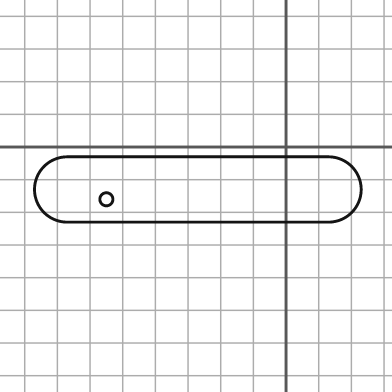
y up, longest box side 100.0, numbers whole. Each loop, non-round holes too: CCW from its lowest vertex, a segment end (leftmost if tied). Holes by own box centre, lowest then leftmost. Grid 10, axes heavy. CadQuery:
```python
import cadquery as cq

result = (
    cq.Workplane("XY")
    .moveTo(-67.0, -23.0)
    .lineTo(13.0, -23.0)
    .threePointArc((23.0, -13.0), (13.0, -3.0))
    .lineTo(-67.0, -3.0)
    .threePointArc((-77.0, -13.0), (-67.0, -23.0))
    .close()
    .moveTo(-55.0, -16.0)
    .circle(2.0)
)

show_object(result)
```